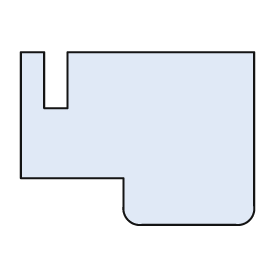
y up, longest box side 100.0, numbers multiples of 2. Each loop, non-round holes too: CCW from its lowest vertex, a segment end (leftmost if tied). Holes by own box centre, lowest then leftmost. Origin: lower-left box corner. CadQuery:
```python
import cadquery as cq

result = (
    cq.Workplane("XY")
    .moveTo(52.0, 0.0)
    .lineTo(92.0, 0.0)
    .threePointArc((98.0, 2.0), (100.0, 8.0))
    .lineTo(100.0, 74.0)
    .lineTo(20.0, 74.0)
    .lineTo(20.0, 50.0)
    .lineTo(10.0, 50.0)
    .lineTo(10.0, 74.0)
    .lineTo(0.0, 74.0)
    .lineTo(0.0, 20.0)
    .lineTo(44.0, 20.0)
    .lineTo(44.0, 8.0)
    .threePointArc((46.0, 2.0), (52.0, 0.0))
    .close()
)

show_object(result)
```